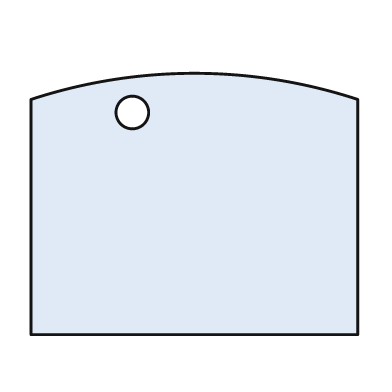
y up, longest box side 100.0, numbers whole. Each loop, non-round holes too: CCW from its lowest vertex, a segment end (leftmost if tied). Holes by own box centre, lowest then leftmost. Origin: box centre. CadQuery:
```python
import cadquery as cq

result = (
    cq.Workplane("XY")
    .moveTo(-50.0, -40.0)
    .lineTo(50.0, -40.0)
    .lineTo(50.0, 32.0)
    .threePointArc((0.0, 40.0), (-50.0, 32.0))
    .close()
    .moveTo(-19.0, 28.0)
    .circle(5.0)
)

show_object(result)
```